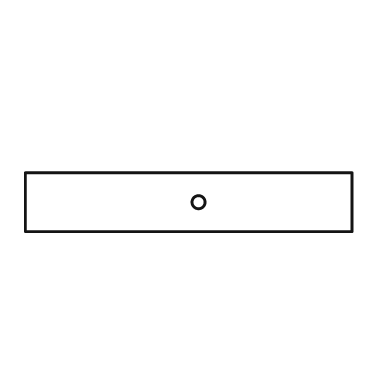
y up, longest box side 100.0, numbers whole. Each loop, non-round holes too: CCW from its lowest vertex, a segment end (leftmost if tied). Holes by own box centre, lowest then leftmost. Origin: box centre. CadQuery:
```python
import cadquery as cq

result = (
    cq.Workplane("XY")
    .moveTo(-50.0, -9.0)
    .lineTo(50.0, -9.0)
    .lineTo(50.0, 9.0)
    .lineTo(-50.0, 9.0)
    .close()
    .moveTo(3.0, 0.0)
    .circle(2.0)
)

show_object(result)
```